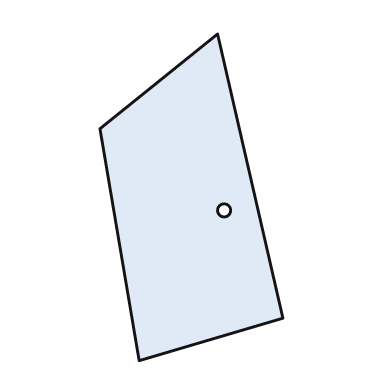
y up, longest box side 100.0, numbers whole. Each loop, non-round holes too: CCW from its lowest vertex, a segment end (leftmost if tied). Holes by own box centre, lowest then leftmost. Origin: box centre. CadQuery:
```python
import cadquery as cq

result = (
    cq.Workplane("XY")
    .moveTo(-16.0, -50.0)
    .lineTo(28.0, -37.0)
    .lineTo(8.0, 50.0)
    .lineTo(-28.0, 21.0)
    .close()
    .moveTo(10.0, -4.0)
    .circle(2.0)
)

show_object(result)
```